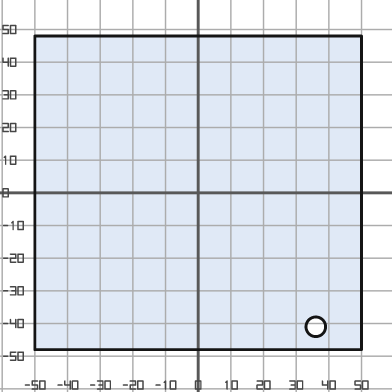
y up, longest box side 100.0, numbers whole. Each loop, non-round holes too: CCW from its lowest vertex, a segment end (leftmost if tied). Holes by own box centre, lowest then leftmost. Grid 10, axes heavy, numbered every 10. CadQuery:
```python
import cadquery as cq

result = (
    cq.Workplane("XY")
    .moveTo(-50.0, -48.0)
    .lineTo(50.0, -48.0)
    .lineTo(50.0, 48.0)
    .lineTo(-50.0, 48.0)
    .close()
    .moveTo(36.0, -41.0)
    .circle(3.0)
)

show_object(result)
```